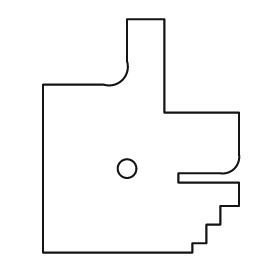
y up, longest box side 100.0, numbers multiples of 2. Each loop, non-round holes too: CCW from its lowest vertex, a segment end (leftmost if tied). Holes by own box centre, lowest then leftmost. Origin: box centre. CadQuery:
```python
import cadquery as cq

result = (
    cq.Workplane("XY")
    .moveTo(-42.0, -50.0)
    .lineTo(22.0, -50.0)
    .lineTo(22.0, -46.0)
    .lineTo(28.0, -46.0)
    .lineTo(28.0, -38.0)
    .lineTo(34.0, -38.0)
    .lineTo(34.0, -30.0)
    .lineTo(42.0, -30.0)
    .lineTo(42.0, -20.0)
    .lineTo(16.0, -20.0)
    .lineTo(16.0, -16.0)
    .lineTo(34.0, -16.0)
    .threePointArc((40.0, -14.0), (42.0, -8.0))
    .lineTo(42.0, 10.0)
    .lineTo(10.0, 10.0)
    .lineTo(10.0, 50.0)
    .lineTo(-6.0, 50.0)
    .lineTo(-6.0, 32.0)
    .threePointArc((-8.0, 24.0), (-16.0, 22.0))
    .lineTo(-42.0, 22.0)
    .close()
    .moveTo(-6.0, -14.0)
    .circle(4.0)
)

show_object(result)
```